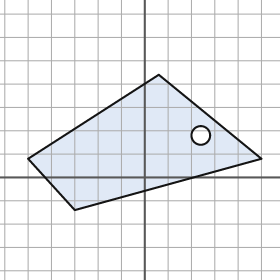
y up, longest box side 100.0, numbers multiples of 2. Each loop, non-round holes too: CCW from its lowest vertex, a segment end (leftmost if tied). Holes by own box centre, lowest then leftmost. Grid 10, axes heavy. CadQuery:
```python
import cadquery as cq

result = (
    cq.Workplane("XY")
    .moveTo(-30.0, -14.0)
    .lineTo(50.0, 8.0)
    .lineTo(6.0, 44.0)
    .lineTo(-50.0, 8.0)
    .close()
    .moveTo(24.0, 18.0)
    .circle(4.0)
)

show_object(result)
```